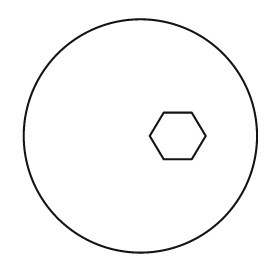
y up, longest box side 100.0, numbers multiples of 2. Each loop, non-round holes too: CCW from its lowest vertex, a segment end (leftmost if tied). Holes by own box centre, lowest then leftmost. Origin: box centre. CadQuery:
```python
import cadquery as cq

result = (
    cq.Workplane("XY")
    .moveTo(0.0, 0.0)
    .circle(50.0)
    .moveTo(10.0, -10.0)
    .lineTo(22.0, -10.0)
    .lineTo(28.0, 0.0)
    .lineTo(22.0, 10.0)
    .lineTo(10.0, 10.0)
    .lineTo(4.0, 0.0)
    .close()
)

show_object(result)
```